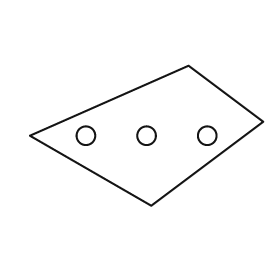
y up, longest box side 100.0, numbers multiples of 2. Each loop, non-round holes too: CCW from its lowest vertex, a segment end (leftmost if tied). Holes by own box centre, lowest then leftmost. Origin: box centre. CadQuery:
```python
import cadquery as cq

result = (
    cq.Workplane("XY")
    .moveTo(2.0, -30.0)
    .lineTo(50.0, 6.0)
    .lineTo(18.0, 30.0)
    .lineTo(-50.0, 0.0)
    .close()
    .moveTo(-26.0, 0.0)
    .circle(4.0)
    .moveTo(0.0, 0.0)
    .circle(4.0)
    .moveTo(26.0, 0.0)
    .circle(4.0)
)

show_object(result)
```